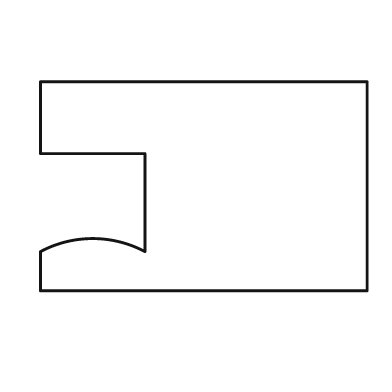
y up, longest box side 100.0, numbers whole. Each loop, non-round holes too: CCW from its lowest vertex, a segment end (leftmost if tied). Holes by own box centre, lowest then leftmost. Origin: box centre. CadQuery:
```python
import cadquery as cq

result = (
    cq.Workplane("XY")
    .moveTo(-50.0, -32.0)
    .lineTo(50.0, -32.0)
    .lineTo(50.0, 32.0)
    .lineTo(-50.0, 32.0)
    .lineTo(-50.0, 10.0)
    .lineTo(-18.0, 10.0)
    .lineTo(-18.0, -20.0)
    .threePointArc((-34.0, -16.0), (-50.0, -20.0))
    .close()
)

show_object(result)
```